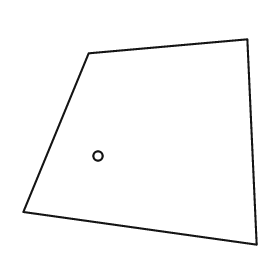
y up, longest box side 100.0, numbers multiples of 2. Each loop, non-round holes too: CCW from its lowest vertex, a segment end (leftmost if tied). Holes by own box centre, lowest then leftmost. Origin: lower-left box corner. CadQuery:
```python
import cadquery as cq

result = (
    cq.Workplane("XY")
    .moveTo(100.0, 0.0)
    .lineTo(96.0, 88.0)
    .lineTo(28.0, 82.0)
    .lineTo(0.0, 14.0)
    .close()
    .moveTo(32.0, 38.0)
    .circle(2.0)
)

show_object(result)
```